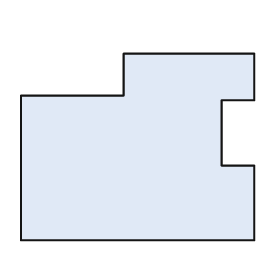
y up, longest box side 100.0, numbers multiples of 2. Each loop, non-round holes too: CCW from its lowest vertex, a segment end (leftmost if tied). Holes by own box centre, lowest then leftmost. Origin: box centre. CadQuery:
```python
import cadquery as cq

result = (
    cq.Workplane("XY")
    .moveTo(-50.0, -40.0)
    .lineTo(50.0, -40.0)
    .lineTo(50.0, -8.0)
    .lineTo(36.0, -8.0)
    .lineTo(36.0, 20.0)
    .lineTo(50.0, 20.0)
    .lineTo(50.0, 40.0)
    .lineTo(-6.0, 40.0)
    .lineTo(-6.0, 22.0)
    .lineTo(-50.0, 22.0)
    .close()
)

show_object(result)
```